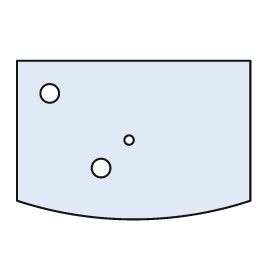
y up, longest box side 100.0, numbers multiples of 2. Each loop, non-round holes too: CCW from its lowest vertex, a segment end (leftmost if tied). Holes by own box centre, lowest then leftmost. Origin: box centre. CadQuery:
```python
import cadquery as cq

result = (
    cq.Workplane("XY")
    .moveTo(-50.0, -26.0)
    .threePointArc((0.0, -34.0), (50.0, -26.0))
    .lineTo(50.0, 34.0)
    .lineTo(-50.0, 34.0)
    .close()
    .moveTo(-14.0, -12.0)
    .circle(4.0)
    .moveTo(-2.0, 0.0)
    .circle(2.0)
    .moveTo(-36.0, 20.0)
    .circle(4.0)
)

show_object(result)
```